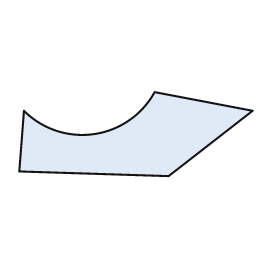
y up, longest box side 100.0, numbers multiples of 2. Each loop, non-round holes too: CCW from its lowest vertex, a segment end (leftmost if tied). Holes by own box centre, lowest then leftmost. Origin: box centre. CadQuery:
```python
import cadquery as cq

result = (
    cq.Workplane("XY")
    .moveTo(14.0, -18.0)
    .lineTo(50.0, 10.0)
    .lineTo(8.0, 18.0)
    .threePointArc((-18.0, 0.0), (-48.0, 10.0))
    .lineTo(-50.0, -16.0)
    .close()
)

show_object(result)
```